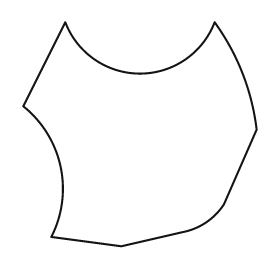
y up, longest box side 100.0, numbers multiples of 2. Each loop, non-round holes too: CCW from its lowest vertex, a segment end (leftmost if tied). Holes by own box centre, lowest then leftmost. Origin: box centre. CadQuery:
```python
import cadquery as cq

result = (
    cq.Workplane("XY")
    .moveTo(-8.0, -48.0)
    .lineTo(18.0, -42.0)
    .threePointArc((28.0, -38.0), (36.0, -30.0))
    .lineTo(50.0, 2.0)
    .threePointArc((44.0, 26.0), (32.0, 48.0))
    .threePointArc((0.0, 26.0), (-32.0, 48.0))
    .lineTo(-50.0, 12.0)
    .threePointArc((-34.0, -14.0), (-38.0, -44.0))
    .close()
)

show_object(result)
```